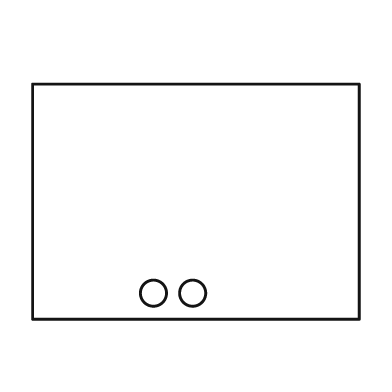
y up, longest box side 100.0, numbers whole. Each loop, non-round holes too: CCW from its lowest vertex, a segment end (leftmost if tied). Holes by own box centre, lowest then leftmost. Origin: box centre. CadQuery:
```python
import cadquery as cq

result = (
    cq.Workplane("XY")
    .moveTo(-50.0, -36.0)
    .lineTo(50.0, -36.0)
    .lineTo(50.0, 36.0)
    .lineTo(-50.0, 36.0)
    .close()
    .moveTo(-13.0, -28.0)
    .circle(4.0)
    .moveTo(-1.0, -28.0)
    .circle(4.0)
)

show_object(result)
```